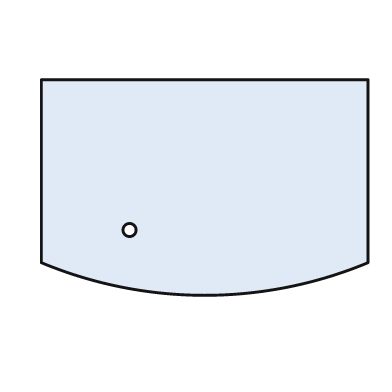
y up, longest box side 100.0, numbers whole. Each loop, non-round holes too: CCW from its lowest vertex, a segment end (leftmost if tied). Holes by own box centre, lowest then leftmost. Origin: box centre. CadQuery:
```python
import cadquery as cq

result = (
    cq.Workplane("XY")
    .moveTo(-50.0, -23.0)
    .threePointArc((0.0, -33.0), (50.0, -23.0))
    .lineTo(50.0, 33.0)
    .lineTo(-50.0, 33.0)
    .close()
    .moveTo(-23.0, -13.0)
    .circle(2.0)
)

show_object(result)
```